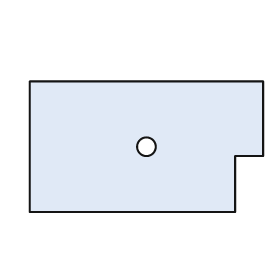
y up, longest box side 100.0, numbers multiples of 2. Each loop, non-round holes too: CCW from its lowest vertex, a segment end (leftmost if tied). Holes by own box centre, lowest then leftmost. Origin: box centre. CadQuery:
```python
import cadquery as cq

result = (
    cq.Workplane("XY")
    .moveTo(-50.0, -28.0)
    .lineTo(38.0, -28.0)
    .lineTo(38.0, -4.0)
    .lineTo(50.0, -4.0)
    .lineTo(50.0, 28.0)
    .lineTo(-50.0, 28.0)
    .close()
    .moveTo(0.0, 0.0)
    .circle(4.0)
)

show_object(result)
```